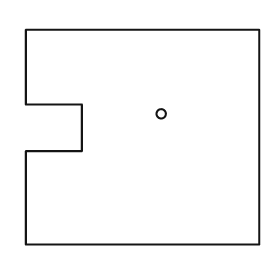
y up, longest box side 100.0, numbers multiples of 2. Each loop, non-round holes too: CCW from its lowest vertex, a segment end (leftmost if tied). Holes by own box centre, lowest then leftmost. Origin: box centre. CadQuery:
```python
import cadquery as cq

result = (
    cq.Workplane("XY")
    .moveTo(-50.0, -46.0)
    .lineTo(50.0, -46.0)
    .lineTo(50.0, 46.0)
    .lineTo(-50.0, 46.0)
    .lineTo(-50.0, 14.0)
    .lineTo(-26.0, 14.0)
    .lineTo(-26.0, -6.0)
    .lineTo(-50.0, -6.0)
    .close()
    .moveTo(8.0, 10.0)
    .circle(2.0)
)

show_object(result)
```